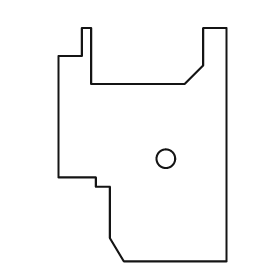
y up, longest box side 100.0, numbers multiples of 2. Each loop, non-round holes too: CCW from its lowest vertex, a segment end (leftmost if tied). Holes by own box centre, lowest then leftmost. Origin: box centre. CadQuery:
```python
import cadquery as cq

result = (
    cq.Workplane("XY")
    .moveTo(-8.0, -50.0)
    .lineTo(36.0, -50.0)
    .lineTo(36.0, 50.0)
    .lineTo(26.0, 50.0)
    .lineTo(26.0, 34.0)
    .lineTo(18.0, 26.0)
    .lineTo(-22.0, 26.0)
    .lineTo(-22.0, 50.0)
    .lineTo(-26.0, 50.0)
    .lineTo(-26.0, 38.0)
    .lineTo(-36.0, 38.0)
    .lineTo(-36.0, -14.0)
    .lineTo(-20.0, -14.0)
    .lineTo(-20.0, -18.0)
    .lineTo(-14.0, -18.0)
    .lineTo(-14.0, -40.0)
    .close()
    .moveTo(10.0, -6.0)
    .circle(4.0)
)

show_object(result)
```